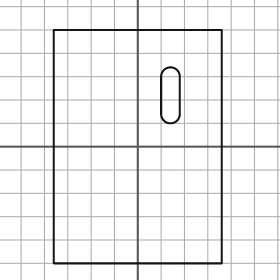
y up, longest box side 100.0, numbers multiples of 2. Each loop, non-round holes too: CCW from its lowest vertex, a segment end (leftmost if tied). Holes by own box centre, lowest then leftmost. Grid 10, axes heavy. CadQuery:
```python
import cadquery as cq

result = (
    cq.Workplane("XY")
    .moveTo(-36.0, -50.0)
    .lineTo(36.0, -50.0)
    .lineTo(36.0, 50.0)
    .lineTo(-36.0, 50.0)
    .close()
    .moveTo(10.0, 14.0)
    .threePointArc((14.0, 10.0), (18.0, 14.0))
    .lineTo(18.0, 30.0)
    .threePointArc((14.0, 34.0), (10.0, 30.0))
    .close()
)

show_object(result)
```